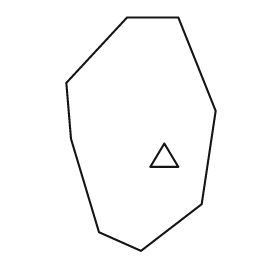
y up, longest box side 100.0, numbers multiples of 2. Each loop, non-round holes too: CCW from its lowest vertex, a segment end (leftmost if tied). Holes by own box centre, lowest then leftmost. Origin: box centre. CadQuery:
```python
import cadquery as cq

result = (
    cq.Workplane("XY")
    .moveTo(0.0, -50.0)
    .lineTo(26.0, -30.0)
    .lineTo(32.0, 10.0)
    .lineTo(16.0, 50.0)
    .lineTo(-6.0, 50.0)
    .lineTo(-32.0, 22.0)
    .lineTo(-30.0, -2.0)
    .lineTo(-18.0, -42.0)
    .close()
    .moveTo(4.0, -14.0)
    .lineTo(16.0, -14.0)
    .lineTo(10.0, -4.0)
    .close()
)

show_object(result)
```